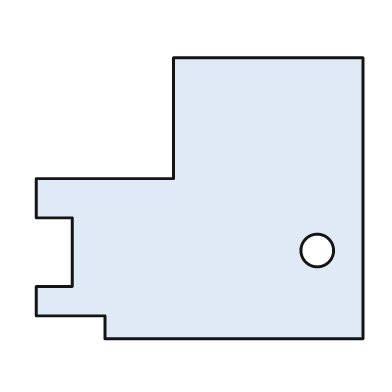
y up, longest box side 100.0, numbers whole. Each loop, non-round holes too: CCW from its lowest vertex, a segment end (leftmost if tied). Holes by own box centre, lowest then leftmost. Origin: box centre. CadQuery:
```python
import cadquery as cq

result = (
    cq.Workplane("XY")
    .moveTo(-29.0, -43.0)
    .lineTo(50.0, -43.0)
    .lineTo(50.0, 43.0)
    .lineTo(-8.0, 43.0)
    .lineTo(-8.0, 6.0)
    .lineTo(-50.0, 6.0)
    .lineTo(-50.0, -6.0)
    .lineTo(-39.0, -6.0)
    .lineTo(-39.0, -27.0)
    .lineTo(-50.0, -27.0)
    .lineTo(-50.0, -36.0)
    .lineTo(-29.0, -36.0)
    .close()
    .moveTo(36.0, -16.0)
    .circle(5.0)
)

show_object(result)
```